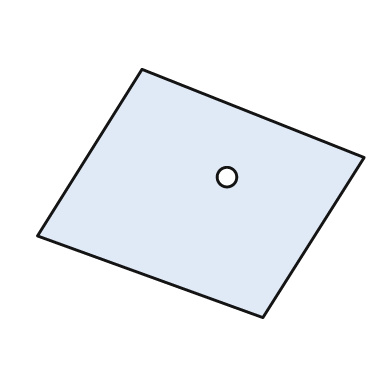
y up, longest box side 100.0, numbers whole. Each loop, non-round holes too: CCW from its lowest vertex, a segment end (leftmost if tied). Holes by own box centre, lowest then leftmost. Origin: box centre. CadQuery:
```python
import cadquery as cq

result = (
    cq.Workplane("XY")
    .moveTo(19.0, -38.0)
    .lineTo(50.0, 11.0)
    .lineTo(-18.0, 38.0)
    .lineTo(-50.0, -13.0)
    .close()
    .moveTo(8.0, 5.0)
    .circle(3.0)
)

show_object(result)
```